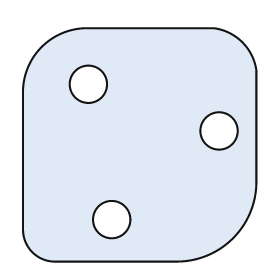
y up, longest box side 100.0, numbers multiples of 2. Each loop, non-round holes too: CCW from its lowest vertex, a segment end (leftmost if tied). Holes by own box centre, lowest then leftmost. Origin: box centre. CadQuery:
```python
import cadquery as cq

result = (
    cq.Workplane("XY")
    .moveTo(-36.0, -50.0)
    .lineTo(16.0, -50.0)
    .threePointArc((40.0, -40.0), (50.0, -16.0))
    .lineTo(50.0, 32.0)
    .threePointArc((44.0, 44.0), (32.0, 50.0))
    .lineTo(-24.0, 50.0)
    .threePointArc((-42.0, 42.0), (-50.0, 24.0))
    .lineTo(-50.0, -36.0)
    .threePointArc((-46.0, -46.0), (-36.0, -50.0))
    .close()
    .moveTo(-12.0, -32.0)
    .circle(8.0)
    .moveTo(34.0, 6.0)
    .circle(8.0)
    .moveTo(-22.0, 26.0)
    .circle(8.0)
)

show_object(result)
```